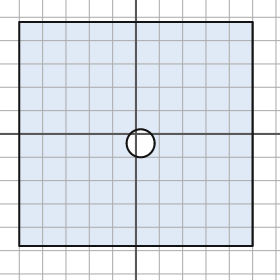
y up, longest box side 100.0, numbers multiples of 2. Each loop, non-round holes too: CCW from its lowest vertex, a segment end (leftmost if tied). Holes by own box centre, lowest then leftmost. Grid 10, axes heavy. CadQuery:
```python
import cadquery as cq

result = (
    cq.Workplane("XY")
    .moveTo(-50.0, -48.0)
    .lineTo(50.0, -48.0)
    .lineTo(50.0, 48.0)
    .lineTo(-50.0, 48.0)
    .close()
    .moveTo(2.0, -4.0)
    .circle(6.0)
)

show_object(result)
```